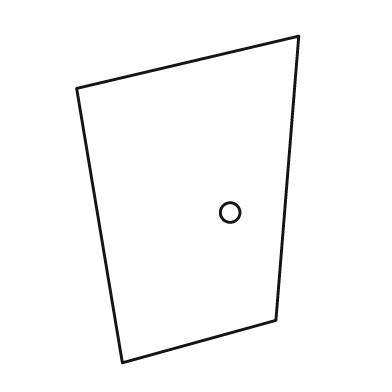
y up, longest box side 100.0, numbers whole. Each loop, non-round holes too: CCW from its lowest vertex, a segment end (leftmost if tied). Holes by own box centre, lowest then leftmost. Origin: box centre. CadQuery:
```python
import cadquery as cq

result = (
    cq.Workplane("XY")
    .moveTo(-20.0, -50.0)
    .lineTo(27.0, -37.0)
    .lineTo(34.0, 50.0)
    .lineTo(-34.0, 34.0)
    .close()
    .moveTo(13.0, -4.0)
    .circle(3.0)
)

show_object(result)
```